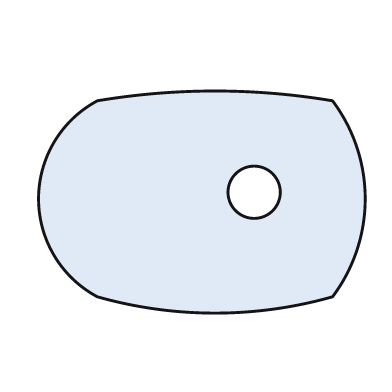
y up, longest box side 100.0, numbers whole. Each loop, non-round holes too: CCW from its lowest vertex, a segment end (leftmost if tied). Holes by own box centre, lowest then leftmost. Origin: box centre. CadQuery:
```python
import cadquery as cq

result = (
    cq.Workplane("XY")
    .moveTo(-32.0, -29.0)
    .threePointArc((4.0, -34.0), (40.0, -29.0))
    .threePointArc((50.0, 1.0), (40.0, 31.0))
    .threePointArc((4.0, 34.0), (-32.0, 31.0))
    .threePointArc((-50.0, 1.0), (-32.0, -29.0))
    .close()
    .moveTo(16.0, 3.0)
    .circle(8.0)
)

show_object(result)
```